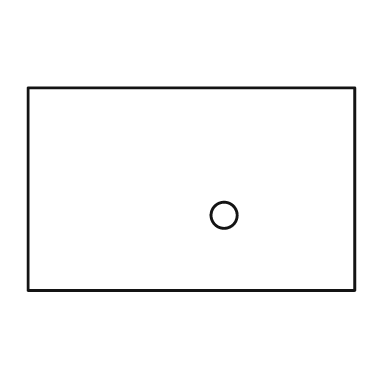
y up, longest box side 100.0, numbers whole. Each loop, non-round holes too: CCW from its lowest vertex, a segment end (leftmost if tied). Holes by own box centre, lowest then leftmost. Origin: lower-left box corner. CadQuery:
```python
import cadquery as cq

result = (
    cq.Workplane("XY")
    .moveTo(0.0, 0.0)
    .lineTo(100.0, 0.0)
    .lineTo(100.0, 62.0)
    .lineTo(0.0, 62.0)
    .close()
    .moveTo(60.0, 23.0)
    .circle(4.0)
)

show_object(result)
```